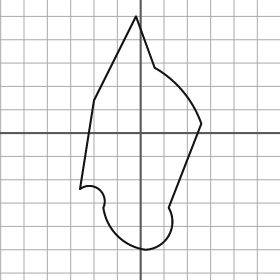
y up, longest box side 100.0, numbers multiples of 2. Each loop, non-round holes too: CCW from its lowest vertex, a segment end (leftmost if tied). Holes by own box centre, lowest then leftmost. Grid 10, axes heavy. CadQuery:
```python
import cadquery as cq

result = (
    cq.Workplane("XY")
    .moveTo(2.0, -50.0)
    .threePointArc((12.0, -44.0), (12.0, -32.0))
    .lineTo(26.0, 4.0)
    .threePointArc((18.0, 18.0), (6.0, 28.0))
    .lineTo(-2.0, 50.0)
    .lineTo(-20.0, 14.0)
    .lineTo(-26.0, -24.0)
    .threePointArc((-18.0, -24.0), (-16.0, -32.0))
    .threePointArc((-10.0, -44.0), (2.0, -50.0))
    .close()
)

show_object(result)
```